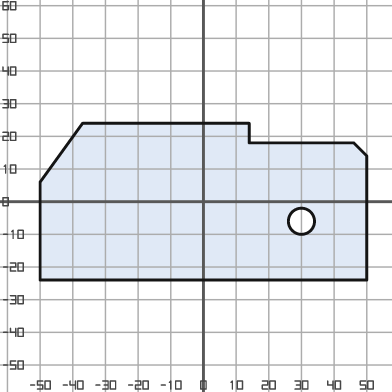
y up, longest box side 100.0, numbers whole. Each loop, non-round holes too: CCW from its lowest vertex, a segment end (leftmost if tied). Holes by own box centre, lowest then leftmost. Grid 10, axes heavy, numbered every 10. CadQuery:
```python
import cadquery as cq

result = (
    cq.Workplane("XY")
    .moveTo(-50.0, -24.0)
    .lineTo(50.0, -24.0)
    .lineTo(50.0, 14.0)
    .lineTo(46.0, 18.0)
    .lineTo(14.0, 18.0)
    .lineTo(14.0, 24.0)
    .lineTo(-37.0, 24.0)
    .lineTo(-50.0, 6.0)
    .close()
    .moveTo(30.0, -6.0)
    .circle(4.0)
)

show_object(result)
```